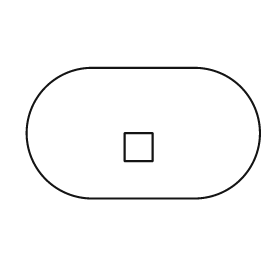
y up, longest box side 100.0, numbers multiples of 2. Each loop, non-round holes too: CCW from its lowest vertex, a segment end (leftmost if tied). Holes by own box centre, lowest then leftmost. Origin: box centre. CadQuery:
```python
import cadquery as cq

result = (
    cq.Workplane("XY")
    .moveTo(-22.0, -28.0)
    .lineTo(22.0, -28.0)
    .threePointArc((50.0, 0.0), (22.0, 28.0))
    .lineTo(-22.0, 28.0)
    .threePointArc((-50.0, 0.0), (-22.0, -28.0))
    .close()
    .moveTo(-8.0, -12.0)
    .lineTo(4.0, -12.0)
    .lineTo(4.0, 0.0)
    .lineTo(-8.0, 0.0)
    .close()
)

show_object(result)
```